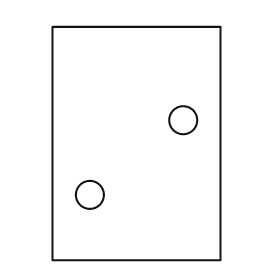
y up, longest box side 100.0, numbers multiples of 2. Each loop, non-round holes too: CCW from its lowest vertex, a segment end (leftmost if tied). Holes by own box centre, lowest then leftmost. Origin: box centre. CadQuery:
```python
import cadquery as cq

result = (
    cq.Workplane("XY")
    .moveTo(-36.0, -50.0)
    .lineTo(36.0, -50.0)
    .lineTo(36.0, 50.0)
    .lineTo(-36.0, 50.0)
    .close()
    .moveTo(-20.0, -22.0)
    .circle(6.0)
    .moveTo(20.0, 10.0)
    .circle(6.0)
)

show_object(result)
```